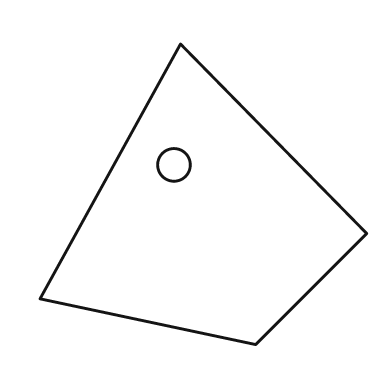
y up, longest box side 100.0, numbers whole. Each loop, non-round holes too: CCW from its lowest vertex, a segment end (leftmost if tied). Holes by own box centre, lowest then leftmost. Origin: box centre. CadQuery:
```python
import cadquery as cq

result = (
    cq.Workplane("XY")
    .moveTo(16.0, -46.0)
    .lineTo(50.0, -12.0)
    .lineTo(-7.0, 46.0)
    .lineTo(-50.0, -32.0)
    .close()
    .moveTo(-9.0, 9.0)
    .circle(5.0)
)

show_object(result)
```